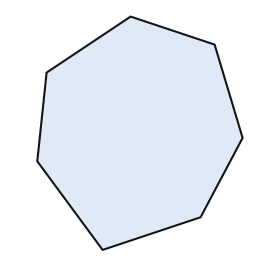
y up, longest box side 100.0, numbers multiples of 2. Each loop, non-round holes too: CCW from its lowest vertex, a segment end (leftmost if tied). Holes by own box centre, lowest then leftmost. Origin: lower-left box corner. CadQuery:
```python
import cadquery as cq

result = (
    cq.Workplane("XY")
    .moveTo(28.0, 0.0)
    .lineTo(70.0, 14.0)
    .lineTo(88.0, 48.0)
    .lineTo(76.0, 88.0)
    .lineTo(40.0, 100.0)
    .lineTo(4.0, 76.0)
    .lineTo(0.0, 38.0)
    .close()
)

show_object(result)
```